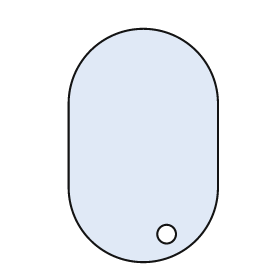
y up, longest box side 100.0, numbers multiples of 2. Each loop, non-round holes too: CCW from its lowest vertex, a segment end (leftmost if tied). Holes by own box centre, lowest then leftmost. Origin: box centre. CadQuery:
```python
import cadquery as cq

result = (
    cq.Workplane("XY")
    .moveTo(-32.0, -18.0)
    .threePointArc((0.0, -50.0), (32.0, -18.0))
    .lineTo(32.0, 18.0)
    .threePointArc((0.0, 50.0), (-32.0, 18.0))
    .close()
    .moveTo(10.0, -38.0)
    .circle(4.0)
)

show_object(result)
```